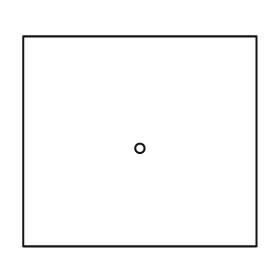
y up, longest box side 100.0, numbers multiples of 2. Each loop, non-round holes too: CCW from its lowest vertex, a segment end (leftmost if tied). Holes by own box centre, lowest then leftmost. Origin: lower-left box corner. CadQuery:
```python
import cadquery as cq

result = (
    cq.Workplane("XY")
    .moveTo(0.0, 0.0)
    .lineTo(100.0, 0.0)
    .lineTo(100.0, 90.0)
    .lineTo(0.0, 90.0)
    .close()
    .moveTo(50.0, 42.0)
    .circle(2.0)
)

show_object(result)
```